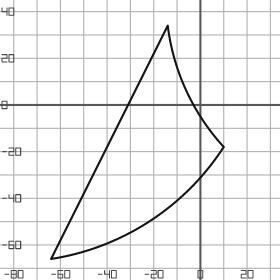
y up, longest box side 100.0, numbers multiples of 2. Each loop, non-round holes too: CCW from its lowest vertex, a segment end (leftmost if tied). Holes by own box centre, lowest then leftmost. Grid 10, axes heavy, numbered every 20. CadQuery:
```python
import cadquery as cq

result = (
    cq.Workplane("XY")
    .moveTo(-64.0, -66.0)
    .threePointArc((-22.0, -50.0), (10.0, -18.0))
    .threePointArc((-6.0, 6.0), (-14.0, 34.0))
    .close()
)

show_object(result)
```